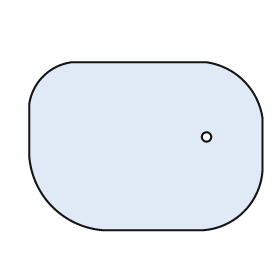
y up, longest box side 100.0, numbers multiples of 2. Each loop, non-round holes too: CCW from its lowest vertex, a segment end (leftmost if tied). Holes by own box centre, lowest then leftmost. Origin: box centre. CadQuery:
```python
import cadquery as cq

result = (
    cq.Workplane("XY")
    .moveTo(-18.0, -36.0)
    .lineTo(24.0, -36.0)
    .threePointArc((42.0, -28.0), (50.0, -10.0))
    .lineTo(50.0, 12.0)
    .threePointArc((42.0, 28.0), (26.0, 36.0))
    .lineTo(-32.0, 36.0)
    .threePointArc((-44.0, 30.0), (-50.0, 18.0))
    .lineTo(-50.0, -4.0)
    .threePointArc((-40.0, -26.0), (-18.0, -36.0))
    .close()
    .moveTo(26.0, 4.0)
    .circle(2.0)
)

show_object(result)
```